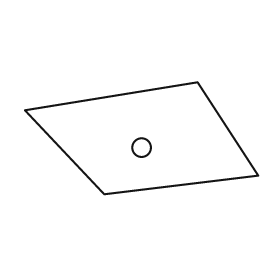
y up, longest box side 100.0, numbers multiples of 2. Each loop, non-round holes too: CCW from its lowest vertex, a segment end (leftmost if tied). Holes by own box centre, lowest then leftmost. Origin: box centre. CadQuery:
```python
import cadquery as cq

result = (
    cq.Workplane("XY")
    .moveTo(-16.0, -24.0)
    .lineTo(50.0, -16.0)
    .lineTo(24.0, 24.0)
    .lineTo(-50.0, 12.0)
    .close()
    .moveTo(0.0, -4.0)
    .circle(4.0)
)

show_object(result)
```